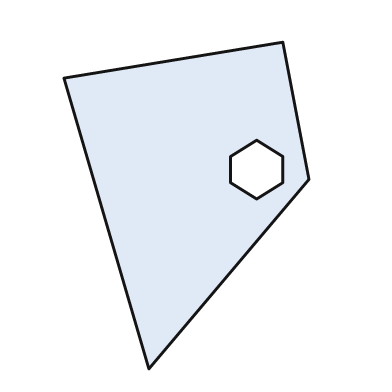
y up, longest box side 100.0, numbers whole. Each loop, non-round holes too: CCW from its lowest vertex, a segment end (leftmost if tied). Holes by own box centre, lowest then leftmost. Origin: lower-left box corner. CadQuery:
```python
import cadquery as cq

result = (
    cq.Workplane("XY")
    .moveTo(26.0, 0.0)
    .lineTo(75.0, 58.0)
    .lineTo(67.0, 100.0)
    .lineTo(0.0, 89.0)
    .close()
    .moveTo(59.0, 52.0)
    .lineTo(67.0, 57.0)
    .lineTo(67.0, 65.0)
    .lineTo(59.0, 70.0)
    .lineTo(51.0, 65.0)
    .lineTo(51.0, 57.0)
    .close()
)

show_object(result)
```